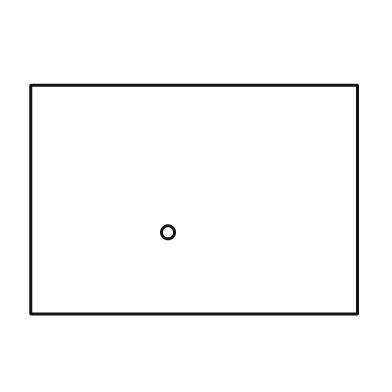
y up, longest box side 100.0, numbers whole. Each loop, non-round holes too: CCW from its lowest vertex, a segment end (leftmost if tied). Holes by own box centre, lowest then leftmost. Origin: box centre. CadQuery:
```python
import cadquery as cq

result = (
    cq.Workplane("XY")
    .moveTo(-50.0, -35.0)
    .lineTo(50.0, -35.0)
    .lineTo(50.0, 35.0)
    .lineTo(-50.0, 35.0)
    .close()
    .moveTo(-8.0, -10.0)
    .circle(2.0)
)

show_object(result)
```